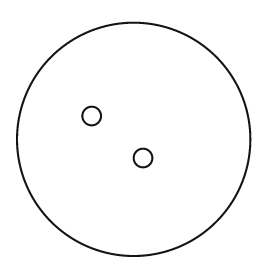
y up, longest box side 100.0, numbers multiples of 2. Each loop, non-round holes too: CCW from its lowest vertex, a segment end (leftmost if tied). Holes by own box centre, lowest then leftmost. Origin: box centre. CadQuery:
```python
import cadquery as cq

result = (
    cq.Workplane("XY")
    .moveTo(0.0, 0.0)
    .circle(50.0)
    .moveTo(4.0, -8.0)
    .circle(4.0)
    .moveTo(-18.0, 10.0)
    .circle(4.0)
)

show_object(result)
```